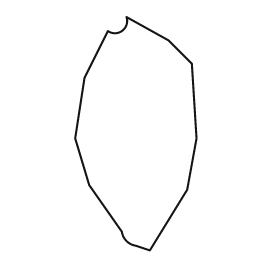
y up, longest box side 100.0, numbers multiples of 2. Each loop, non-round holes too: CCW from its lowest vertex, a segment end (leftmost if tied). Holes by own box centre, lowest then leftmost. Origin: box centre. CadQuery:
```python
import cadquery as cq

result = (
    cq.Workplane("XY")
    .moveTo(6.0, -50.0)
    .lineTo(22.0, -24.0)
    .lineTo(26.0, -2.0)
    .lineTo(24.0, 30.0)
    .lineTo(14.0, 40.0)
    .lineTo(-4.0, 50.0)
    .threePointArc((-6.0, 44.0), (-12.0, 44.0))
    .lineTo(-22.0, 24.0)
    .lineTo(-26.0, -2.0)
    .lineTo(-20.0, -22.0)
    .lineTo(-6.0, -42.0)
    .threePointArc((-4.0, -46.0), (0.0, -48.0))
    .close()
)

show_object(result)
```